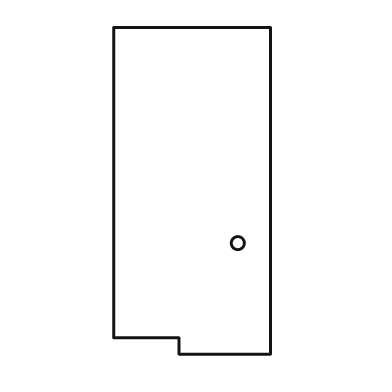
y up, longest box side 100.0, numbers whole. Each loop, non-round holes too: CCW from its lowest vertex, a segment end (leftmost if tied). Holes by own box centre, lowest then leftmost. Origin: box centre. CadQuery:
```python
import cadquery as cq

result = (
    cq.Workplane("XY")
    .moveTo(-4.0, -50.0)
    .lineTo(24.0, -50.0)
    .lineTo(24.0, 50.0)
    .lineTo(-24.0, 50.0)
    .lineTo(-24.0, -45.0)
    .lineTo(-4.0, -45.0)
    .close()
    .moveTo(14.0, -16.0)
    .circle(2.0)
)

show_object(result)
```